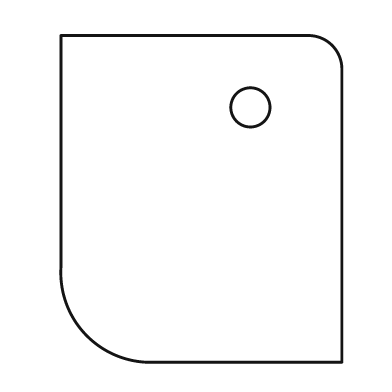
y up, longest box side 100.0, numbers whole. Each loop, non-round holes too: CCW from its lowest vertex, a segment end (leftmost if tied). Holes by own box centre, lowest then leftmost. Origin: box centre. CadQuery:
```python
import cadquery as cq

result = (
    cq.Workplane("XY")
    .moveTo(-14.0, -50.0)
    .lineTo(43.0, -50.0)
    .lineTo(43.0, 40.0)
    .threePointArc((40.0, 47.0), (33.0, 50.0))
    .lineTo(-43.0, 50.0)
    .lineTo(-43.0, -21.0)
    .threePointArc((-35.0, -42.0), (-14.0, -50.0))
    .close()
    .moveTo(15.0, 28.0)
    .circle(6.0)
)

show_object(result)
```